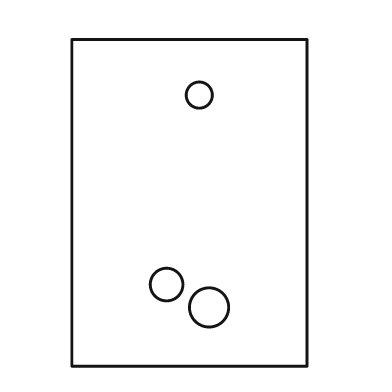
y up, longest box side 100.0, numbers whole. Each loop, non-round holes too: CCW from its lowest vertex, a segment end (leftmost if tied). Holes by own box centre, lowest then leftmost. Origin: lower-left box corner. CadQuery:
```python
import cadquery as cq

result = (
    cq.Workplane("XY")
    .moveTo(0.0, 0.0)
    .lineTo(72.0, 0.0)
    .lineTo(72.0, 100.0)
    .lineTo(0.0, 100.0)
    .close()
    .moveTo(42.0, 18.0)
    .circle(6.0)
    .moveTo(29.0, 25.0)
    .circle(5.0)
    .moveTo(39.0, 83.0)
    .circle(4.0)
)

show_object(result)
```